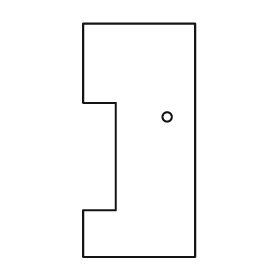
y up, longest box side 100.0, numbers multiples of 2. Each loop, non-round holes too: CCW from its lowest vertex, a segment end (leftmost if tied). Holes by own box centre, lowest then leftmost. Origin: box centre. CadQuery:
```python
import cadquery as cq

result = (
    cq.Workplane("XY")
    .moveTo(-24.0, -50.0)
    .lineTo(24.0, -50.0)
    .lineTo(24.0, 50.0)
    .lineTo(-24.0, 50.0)
    .lineTo(-24.0, 16.0)
    .lineTo(-10.0, 16.0)
    .lineTo(-10.0, -30.0)
    .lineTo(-24.0, -30.0)
    .close()
    .moveTo(12.0, 10.0)
    .circle(2.0)
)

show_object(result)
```